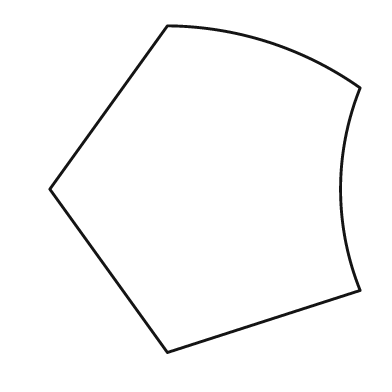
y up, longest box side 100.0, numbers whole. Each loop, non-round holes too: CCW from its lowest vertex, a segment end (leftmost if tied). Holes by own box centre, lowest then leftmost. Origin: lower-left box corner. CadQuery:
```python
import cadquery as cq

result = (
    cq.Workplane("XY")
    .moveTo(36.0, 0.0)
    .lineTo(95.0, 19.0)
    .threePointArc((89.0, 50.0), (95.0, 81.0))
    .threePointArc((67.0, 95.0), (36.0, 100.0))
    .lineTo(0.0, 50.0)
    .close()
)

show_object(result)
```